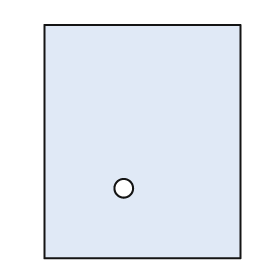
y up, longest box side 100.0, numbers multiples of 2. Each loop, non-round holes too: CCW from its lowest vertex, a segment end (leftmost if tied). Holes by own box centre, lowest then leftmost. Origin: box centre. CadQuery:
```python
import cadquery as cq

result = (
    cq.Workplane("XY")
    .moveTo(-42.0, -50.0)
    .lineTo(42.0, -50.0)
    .lineTo(42.0, 50.0)
    .lineTo(-42.0, 50.0)
    .close()
    .moveTo(-8.0, -20.0)
    .circle(4.0)
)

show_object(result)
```